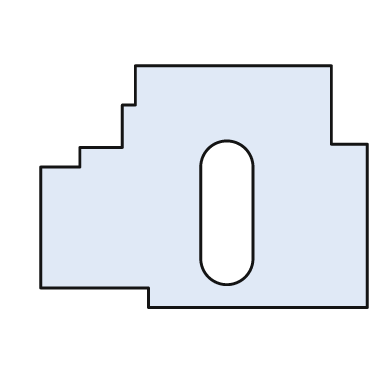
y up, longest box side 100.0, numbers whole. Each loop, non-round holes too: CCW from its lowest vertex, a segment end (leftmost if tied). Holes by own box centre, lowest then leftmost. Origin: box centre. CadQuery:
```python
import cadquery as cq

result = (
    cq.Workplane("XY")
    .moveTo(-17.0, -37.0)
    .lineTo(50.0, -37.0)
    .lineTo(50.0, 13.0)
    .lineTo(39.0, 13.0)
    .lineTo(39.0, 37.0)
    .lineTo(-21.0, 37.0)
    .lineTo(-21.0, 25.0)
    .lineTo(-25.0, 25.0)
    .lineTo(-25.0, 12.0)
    .lineTo(-38.0, 12.0)
    .lineTo(-38.0, 6.0)
    .lineTo(-50.0, 6.0)
    .lineTo(-50.0, -31.0)
    .lineTo(-17.0, -31.0)
    .close()
    .moveTo(-1.0, -22.0)
    .threePointArc((7.0, -30.0), (15.0, -22.0))
    .lineTo(15.0, 6.0)
    .threePointArc((7.0, 14.0), (-1.0, 6.0))
    .close()
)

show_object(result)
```